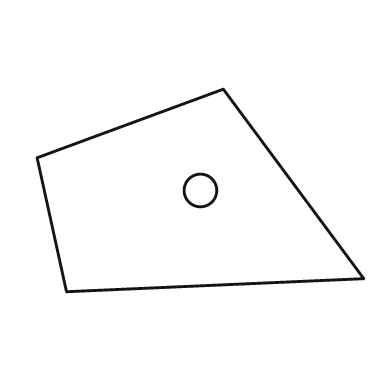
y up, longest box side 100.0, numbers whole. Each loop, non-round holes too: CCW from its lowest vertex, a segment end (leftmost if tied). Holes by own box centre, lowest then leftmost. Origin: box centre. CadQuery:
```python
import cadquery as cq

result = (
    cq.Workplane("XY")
    .moveTo(-41.0, -31.0)
    .lineTo(50.0, -27.0)
    .lineTo(7.0, 31.0)
    .lineTo(-50.0, 10.0)
    .close()
    .moveTo(0.0, 0.0)
    .circle(5.0)
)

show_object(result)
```